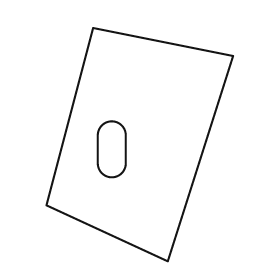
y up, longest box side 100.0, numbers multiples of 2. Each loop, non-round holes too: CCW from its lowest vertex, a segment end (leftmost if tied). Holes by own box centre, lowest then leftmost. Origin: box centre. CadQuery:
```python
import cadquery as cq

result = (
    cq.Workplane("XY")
    .moveTo(12.0, -50.0)
    .lineTo(40.0, 38.0)
    .lineTo(-20.0, 50.0)
    .lineTo(-40.0, -26.0)
    .close()
    .moveTo(-18.0, -8.0)
    .threePointArc((-12.0, -14.0), (-6.0, -8.0))
    .lineTo(-6.0, 4.0)
    .threePointArc((-12.0, 10.0), (-18.0, 4.0))
    .close()
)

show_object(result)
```